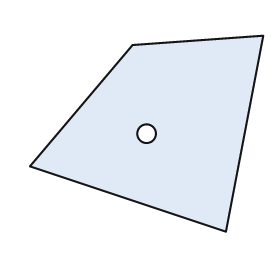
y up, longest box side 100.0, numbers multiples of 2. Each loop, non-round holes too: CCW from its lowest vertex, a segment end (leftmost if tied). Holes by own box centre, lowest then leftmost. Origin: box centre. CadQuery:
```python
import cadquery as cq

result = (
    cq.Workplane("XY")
    .moveTo(34.0, -42.0)
    .lineTo(50.0, 42.0)
    .lineTo(-6.0, 38.0)
    .lineTo(-50.0, -14.0)
    .close()
    .moveTo(0.0, 0.0)
    .circle(4.0)
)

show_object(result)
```